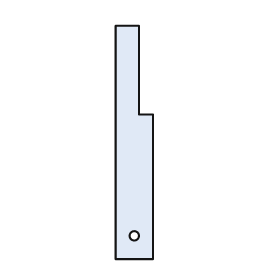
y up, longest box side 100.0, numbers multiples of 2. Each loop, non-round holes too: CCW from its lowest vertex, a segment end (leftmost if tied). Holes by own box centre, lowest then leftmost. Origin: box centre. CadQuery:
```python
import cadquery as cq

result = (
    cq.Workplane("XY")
    .moveTo(-8.0, -50.0)
    .lineTo(8.0, -50.0)
    .lineTo(8.0, 12.0)
    .lineTo(2.0, 12.0)
    .lineTo(2.0, 50.0)
    .lineTo(-8.0, 50.0)
    .close()
    .moveTo(0.0, -40.0)
    .circle(2.0)
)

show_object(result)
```